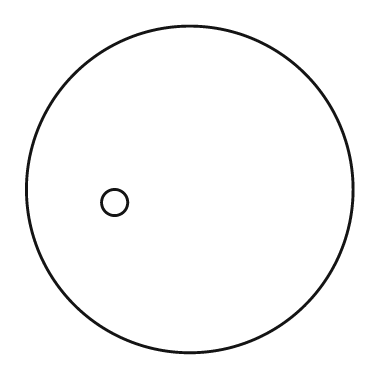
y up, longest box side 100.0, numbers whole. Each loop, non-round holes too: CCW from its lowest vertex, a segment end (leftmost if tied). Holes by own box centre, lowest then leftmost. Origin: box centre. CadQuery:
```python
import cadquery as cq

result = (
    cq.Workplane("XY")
    .moveTo(0.0, 0.0)
    .circle(50.0)
    .moveTo(-23.0, -4.0)
    .circle(4.0)
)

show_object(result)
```